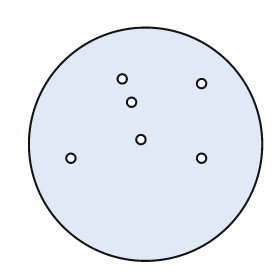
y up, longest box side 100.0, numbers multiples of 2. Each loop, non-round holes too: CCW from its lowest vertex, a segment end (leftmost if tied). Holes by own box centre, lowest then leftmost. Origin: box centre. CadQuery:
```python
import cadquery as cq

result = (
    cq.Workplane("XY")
    .moveTo(0.0, 0.0)
    .circle(50.0)
    .moveTo(-32.0, -6.0)
    .circle(2.0)
    .moveTo(24.0, -6.0)
    .circle(2.0)
    .moveTo(-2.0, 2.0)
    .circle(2.0)
    .moveTo(-6.0, 18.0)
    .circle(2.0)
    .moveTo(24.0, 26.0)
    .circle(2.0)
    .moveTo(-10.0, 28.0)
    .circle(2.0)
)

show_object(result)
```